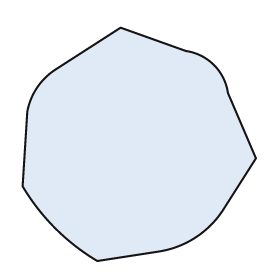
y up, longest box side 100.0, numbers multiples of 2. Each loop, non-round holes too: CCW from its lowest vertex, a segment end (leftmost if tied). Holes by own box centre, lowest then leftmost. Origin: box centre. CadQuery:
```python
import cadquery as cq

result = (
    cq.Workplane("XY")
    .moveTo(-18.0, -50.0)
    .lineTo(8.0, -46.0)
    .threePointArc((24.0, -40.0), (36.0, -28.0))
    .lineTo(50.0, -6.0)
    .lineTo(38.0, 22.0)
    .threePointArc((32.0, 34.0), (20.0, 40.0))
    .lineTo(-8.0, 50.0)
    .lineTo(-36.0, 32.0)
    .threePointArc((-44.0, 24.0), (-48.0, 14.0))
    .lineTo(-50.0, -18.0)
    .threePointArc((-36.0, -36.0), (-18.0, -50.0))
    .close()
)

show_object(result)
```